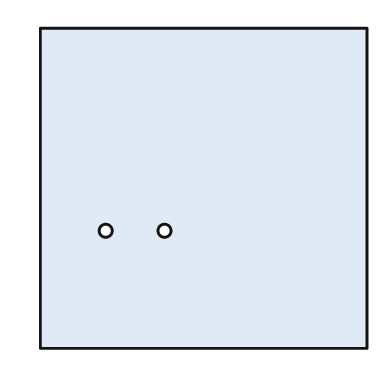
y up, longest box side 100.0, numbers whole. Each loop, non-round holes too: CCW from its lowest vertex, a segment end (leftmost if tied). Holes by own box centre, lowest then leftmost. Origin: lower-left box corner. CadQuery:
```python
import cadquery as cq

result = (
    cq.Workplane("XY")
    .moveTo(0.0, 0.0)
    .lineTo(100.0, 0.0)
    .lineTo(100.0, 98.0)
    .lineTo(0.0, 98.0)
    .close()
    .moveTo(20.0, 36.0)
    .circle(2.0)
    .moveTo(38.0, 36.0)
    .circle(2.0)
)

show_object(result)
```